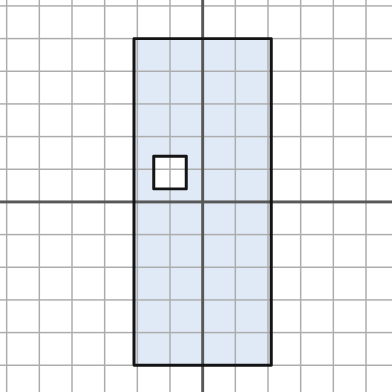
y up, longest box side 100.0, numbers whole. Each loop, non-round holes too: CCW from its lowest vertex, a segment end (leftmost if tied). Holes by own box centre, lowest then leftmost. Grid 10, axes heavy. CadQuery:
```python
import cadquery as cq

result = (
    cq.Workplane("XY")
    .moveTo(-21.0, -50.0)
    .lineTo(21.0, -50.0)
    .lineTo(21.0, 50.0)
    .lineTo(-21.0, 50.0)
    .close()
    .moveTo(-15.0, 4.0)
    .lineTo(-5.0, 4.0)
    .lineTo(-5.0, 14.0)
    .lineTo(-15.0, 14.0)
    .close()
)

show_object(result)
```